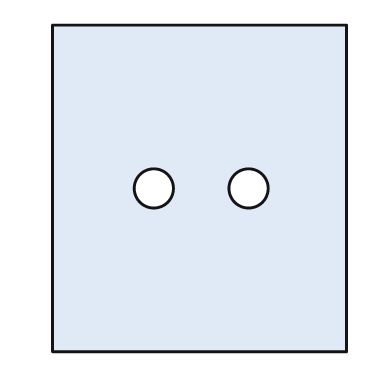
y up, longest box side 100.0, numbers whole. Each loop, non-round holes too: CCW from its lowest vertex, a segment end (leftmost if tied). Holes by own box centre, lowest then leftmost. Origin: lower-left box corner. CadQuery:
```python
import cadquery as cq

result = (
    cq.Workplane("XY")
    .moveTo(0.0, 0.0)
    .lineTo(90.0, 0.0)
    .lineTo(90.0, 100.0)
    .lineTo(0.0, 100.0)
    .close()
    .moveTo(31.0, 50.0)
    .circle(6.0)
    .moveTo(60.0, 50.0)
    .circle(6.0)
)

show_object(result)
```